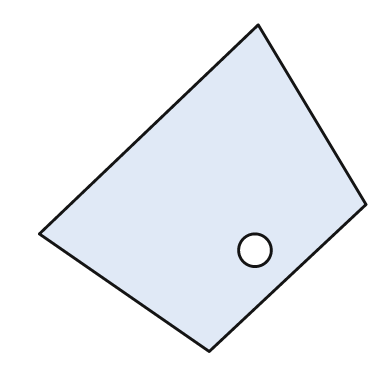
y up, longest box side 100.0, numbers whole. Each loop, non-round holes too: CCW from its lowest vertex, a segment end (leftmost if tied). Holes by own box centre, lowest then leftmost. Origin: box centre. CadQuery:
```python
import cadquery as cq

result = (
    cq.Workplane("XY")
    .moveTo(2.0, -50.0)
    .lineTo(50.0, -5.0)
    .lineTo(17.0, 50.0)
    .lineTo(-50.0, -14.0)
    .close()
    .moveTo(16.0, -19.0)
    .circle(5.0)
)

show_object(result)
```